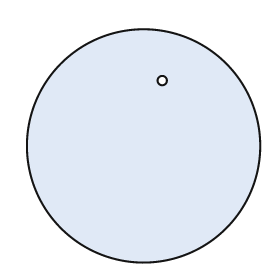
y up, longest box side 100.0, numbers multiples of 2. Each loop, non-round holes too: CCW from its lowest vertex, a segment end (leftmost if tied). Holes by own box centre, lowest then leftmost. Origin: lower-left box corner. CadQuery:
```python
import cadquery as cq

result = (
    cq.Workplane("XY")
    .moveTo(50.0, 50.0)
    .circle(50.0)
    .moveTo(58.0, 78.0)
    .circle(2.0)
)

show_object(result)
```